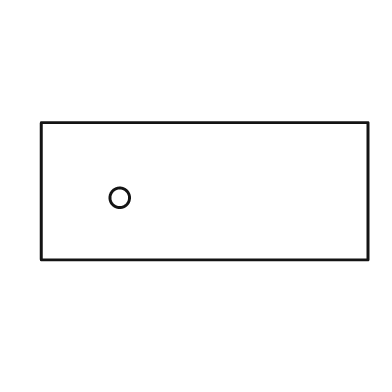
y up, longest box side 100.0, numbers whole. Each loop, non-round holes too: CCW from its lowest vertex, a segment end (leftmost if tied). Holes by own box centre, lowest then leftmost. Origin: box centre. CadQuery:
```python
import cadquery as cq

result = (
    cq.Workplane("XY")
    .moveTo(-50.0, -21.0)
    .lineTo(50.0, -21.0)
    .lineTo(50.0, 21.0)
    .lineTo(-50.0, 21.0)
    .close()
    .moveTo(-26.0, -2.0)
    .circle(3.0)
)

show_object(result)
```